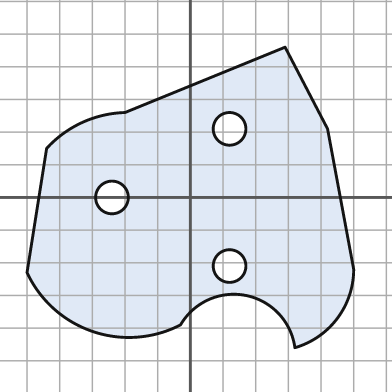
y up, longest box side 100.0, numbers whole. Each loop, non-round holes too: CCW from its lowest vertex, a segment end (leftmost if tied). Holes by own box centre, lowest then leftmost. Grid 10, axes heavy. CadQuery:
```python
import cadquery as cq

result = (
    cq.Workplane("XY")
    .moveTo(32.0, -46.0)
    .threePointArc((45.0, -37.0), (50.0, -22.0))
    .lineTo(42.0, 21.0)
    .lineTo(29.0, 46.0)
    .lineTo(-20.0, 26.0)
    .threePointArc((-33.0, 23.0), (-44.0, 15.0))
    .lineTo(-50.0, -23.0)
    .threePointArc((-30.0, -41.0), (-3.0, -39.0))
    .threePointArc((17.0, -30.0), (32.0, -46.0))
    .close()
    .moveTo(12.0, -21.0)
    .circle(5.0)
    .moveTo(-24.0, 0.0)
    .circle(5.0)
    .moveTo(12.0, 21.0)
    .circle(5.0)
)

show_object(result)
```